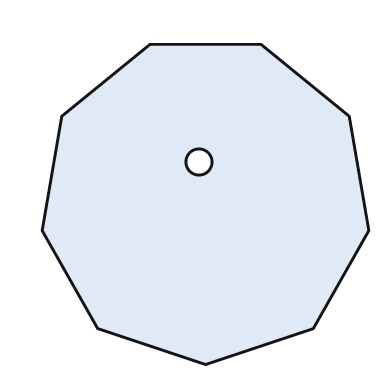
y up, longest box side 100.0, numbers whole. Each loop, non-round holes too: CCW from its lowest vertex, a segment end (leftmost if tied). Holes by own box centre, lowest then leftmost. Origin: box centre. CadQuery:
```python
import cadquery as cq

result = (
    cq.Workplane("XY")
    .moveTo(0.0, -49.0)
    .lineTo(33.0, -38.0)
    .lineTo(50.0, -8.0)
    .lineTo(44.0, 27.0)
    .lineTo(17.0, 49.0)
    .lineTo(-17.0, 49.0)
    .lineTo(-44.0, 27.0)
    .lineTo(-50.0, -8.0)
    .lineTo(-33.0, -38.0)
    .close()
    .moveTo(-2.0, 13.0)
    .circle(4.0)
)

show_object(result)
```